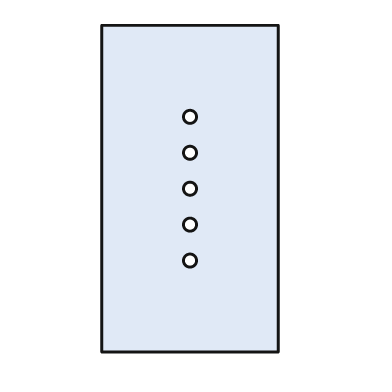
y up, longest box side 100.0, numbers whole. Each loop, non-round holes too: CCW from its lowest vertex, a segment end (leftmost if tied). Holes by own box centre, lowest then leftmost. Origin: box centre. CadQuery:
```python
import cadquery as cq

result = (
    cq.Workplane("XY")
    .moveTo(-27.0, -50.0)
    .lineTo(27.0, -50.0)
    .lineTo(27.0, 50.0)
    .lineTo(-27.0, 50.0)
    .close()
    .moveTo(0.0, -22.0)
    .circle(2.0)
    .moveTo(0.0, -11.0)
    .circle(2.0)
    .moveTo(0.0, 0.0)
    .circle(2.0)
    .moveTo(0.0, 11.0)
    .circle(2.0)
    .moveTo(0.0, 22.0)
    .circle(2.0)
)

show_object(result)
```